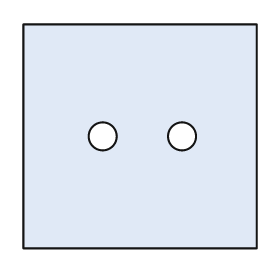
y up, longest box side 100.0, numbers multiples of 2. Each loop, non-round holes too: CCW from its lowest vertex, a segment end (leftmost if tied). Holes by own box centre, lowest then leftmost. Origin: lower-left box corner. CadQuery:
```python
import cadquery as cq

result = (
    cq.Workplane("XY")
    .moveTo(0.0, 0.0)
    .lineTo(100.0, 0.0)
    .lineTo(100.0, 96.0)
    .lineTo(0.0, 96.0)
    .close()
    .moveTo(34.0, 48.0)
    .circle(6.0)
    .moveTo(68.0, 48.0)
    .circle(6.0)
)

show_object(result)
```